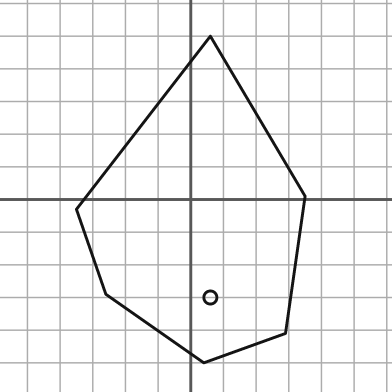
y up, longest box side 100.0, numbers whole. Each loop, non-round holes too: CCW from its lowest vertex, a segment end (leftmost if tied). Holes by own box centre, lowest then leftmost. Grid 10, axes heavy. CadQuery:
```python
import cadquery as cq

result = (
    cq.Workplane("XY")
    .moveTo(4.0, -50.0)
    .lineTo(29.0, -41.0)
    .lineTo(35.0, 1.0)
    .lineTo(6.0, 50.0)
    .lineTo(-35.0, -3.0)
    .lineTo(-26.0, -29.0)
    .close()
    .moveTo(6.0, -30.0)
    .circle(2.0)
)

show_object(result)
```